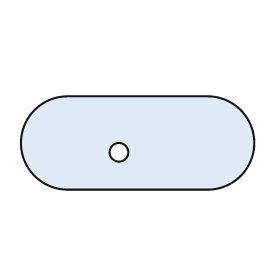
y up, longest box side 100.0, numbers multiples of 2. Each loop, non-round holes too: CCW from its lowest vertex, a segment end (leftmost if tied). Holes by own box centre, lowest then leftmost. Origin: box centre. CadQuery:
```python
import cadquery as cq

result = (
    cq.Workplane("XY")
    .moveTo(-30.0, -20.0)
    .lineTo(30.0, -20.0)
    .threePointArc((50.0, 0.0), (30.0, 20.0))
    .lineTo(-30.0, 20.0)
    .threePointArc((-50.0, 0.0), (-30.0, -20.0))
    .close()
    .moveTo(-8.0, -4.0)
    .circle(4.0)
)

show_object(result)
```